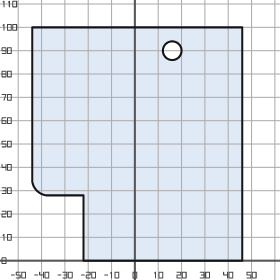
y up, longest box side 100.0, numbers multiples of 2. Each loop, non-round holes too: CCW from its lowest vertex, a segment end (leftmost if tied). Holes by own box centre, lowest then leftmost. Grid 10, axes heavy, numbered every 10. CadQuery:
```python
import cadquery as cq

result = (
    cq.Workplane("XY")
    .moveTo(-22.0, 0.0)
    .lineTo(46.0, 0.0)
    .lineTo(46.0, 100.0)
    .lineTo(-44.0, 100.0)
    .lineTo(-44.0, 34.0)
    .threePointArc((-42.0, 30.0), (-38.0, 28.0))
    .lineTo(-22.0, 28.0)
    .close()
    .moveTo(16.0, 90.0)
    .circle(4.0)
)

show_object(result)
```